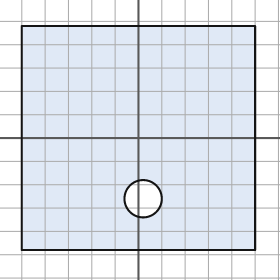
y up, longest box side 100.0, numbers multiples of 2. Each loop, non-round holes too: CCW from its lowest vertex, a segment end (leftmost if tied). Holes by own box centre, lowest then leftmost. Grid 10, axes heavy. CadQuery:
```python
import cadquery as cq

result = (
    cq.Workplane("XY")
    .moveTo(-50.0, -48.0)
    .lineTo(50.0, -48.0)
    .lineTo(50.0, 48.0)
    .lineTo(-50.0, 48.0)
    .close()
    .moveTo(2.0, -26.0)
    .circle(8.0)
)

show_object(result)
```